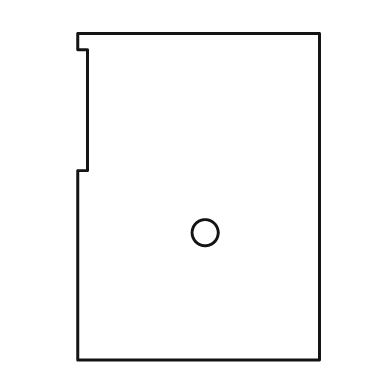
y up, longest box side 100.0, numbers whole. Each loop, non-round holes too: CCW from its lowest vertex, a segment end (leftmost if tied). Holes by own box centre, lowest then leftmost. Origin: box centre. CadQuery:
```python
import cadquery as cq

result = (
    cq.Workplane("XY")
    .moveTo(-37.0, -50.0)
    .lineTo(37.0, -50.0)
    .lineTo(37.0, 50.0)
    .lineTo(-37.0, 50.0)
    .lineTo(-37.0, 45.0)
    .lineTo(-34.0, 45.0)
    .lineTo(-34.0, 8.0)
    .lineTo(-37.0, 8.0)
    .close()
    .moveTo(2.0, -11.0)
    .circle(4.0)
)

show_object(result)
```